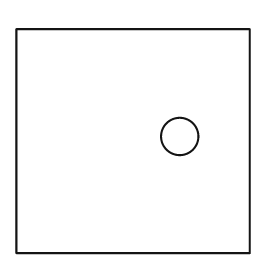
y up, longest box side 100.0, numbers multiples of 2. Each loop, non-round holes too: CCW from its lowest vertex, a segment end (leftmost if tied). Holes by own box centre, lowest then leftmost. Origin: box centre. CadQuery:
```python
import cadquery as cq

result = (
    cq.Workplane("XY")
    .moveTo(-50.0, -48.0)
    .lineTo(50.0, -48.0)
    .lineTo(50.0, 48.0)
    .lineTo(-50.0, 48.0)
    .close()
    .moveTo(20.0, 2.0)
    .circle(8.0)
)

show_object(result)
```